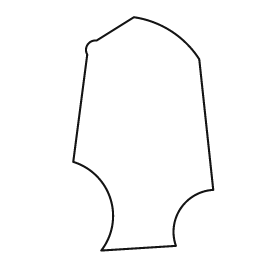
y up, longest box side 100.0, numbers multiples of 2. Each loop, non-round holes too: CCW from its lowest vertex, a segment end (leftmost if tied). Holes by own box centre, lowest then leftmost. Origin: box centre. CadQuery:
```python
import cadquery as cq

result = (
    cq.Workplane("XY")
    .moveTo(-18.0, -50.0)
    .lineTo(14.0, -48.0)
    .threePointArc((16.0, -32.0), (30.0, -24.0))
    .lineTo(24.0, 32.0)
    .threePointArc((12.0, 44.0), (-4.0, 50.0))
    .lineTo(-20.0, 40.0)
    .threePointArc((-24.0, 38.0), (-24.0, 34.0))
    .lineTo(-30.0, -12.0)
    .threePointArc((-14.0, -28.0), (-18.0, -50.0))
    .close()
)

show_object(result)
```